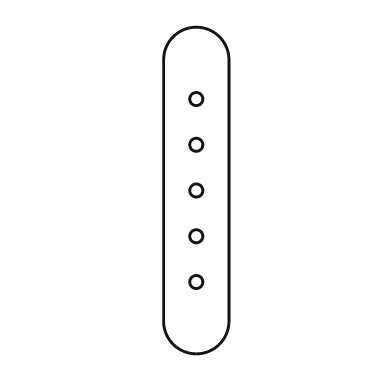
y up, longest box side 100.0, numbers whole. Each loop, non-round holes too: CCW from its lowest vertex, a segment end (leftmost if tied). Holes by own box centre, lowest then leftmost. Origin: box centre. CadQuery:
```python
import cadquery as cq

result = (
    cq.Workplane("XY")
    .moveTo(-10.0, -40.0)
    .threePointArc((0.0, -50.0), (10.0, -40.0))
    .lineTo(10.0, 40.0)
    .threePointArc((0.0, 50.0), (-10.0, 40.0))
    .close()
    .moveTo(0.0, -28.0)
    .circle(2.0)
    .moveTo(0.0, -14.0)
    .circle(2.0)
    .moveTo(0.0, 0.0)
    .circle(2.0)
    .moveTo(0.0, 14.0)
    .circle(2.0)
    .moveTo(0.0, 28.0)
    .circle(2.0)
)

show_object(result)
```